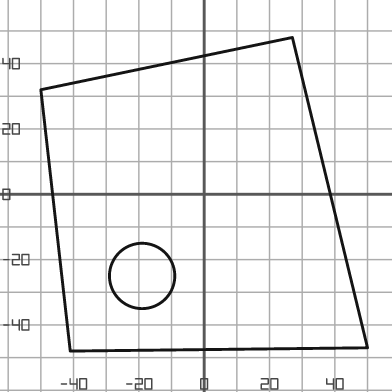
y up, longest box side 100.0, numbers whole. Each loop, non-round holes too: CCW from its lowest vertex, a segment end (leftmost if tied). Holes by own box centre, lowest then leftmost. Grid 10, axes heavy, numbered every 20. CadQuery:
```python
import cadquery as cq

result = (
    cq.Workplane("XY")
    .moveTo(-41.0, -48.0)
    .lineTo(50.0, -47.0)
    .lineTo(27.0, 48.0)
    .lineTo(-50.0, 32.0)
    .close()
    .moveTo(-19.0, -25.0)
    .circle(10.0)
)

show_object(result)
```